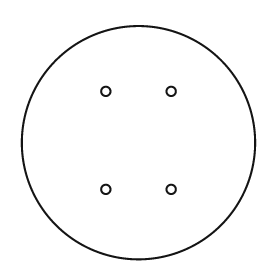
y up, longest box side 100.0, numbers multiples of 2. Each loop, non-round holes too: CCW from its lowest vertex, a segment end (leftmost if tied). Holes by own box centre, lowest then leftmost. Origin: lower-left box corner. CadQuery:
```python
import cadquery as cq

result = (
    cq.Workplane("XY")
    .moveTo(50.0, 50.0)
    .circle(50.0)
    .moveTo(36.0, 30.0)
    .circle(2.0)
    .moveTo(64.0, 30.0)
    .circle(2.0)
    .moveTo(36.0, 72.0)
    .circle(2.0)
    .moveTo(64.0, 72.0)
    .circle(2.0)
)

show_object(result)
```